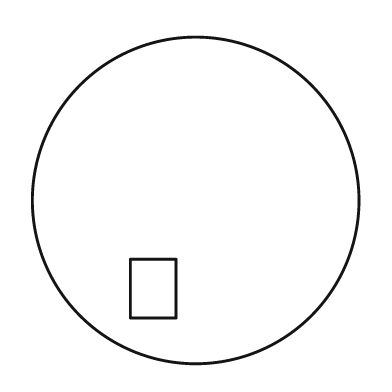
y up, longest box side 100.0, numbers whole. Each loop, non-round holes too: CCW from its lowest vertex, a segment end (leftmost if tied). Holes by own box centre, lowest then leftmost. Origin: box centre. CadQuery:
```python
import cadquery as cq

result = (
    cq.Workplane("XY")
    .moveTo(0.0, 0.0)
    .circle(50.0)
    .moveTo(-20.0, -36.0)
    .lineTo(-6.0, -36.0)
    .lineTo(-6.0, -18.0)
    .lineTo(-20.0, -18.0)
    .close()
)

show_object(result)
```